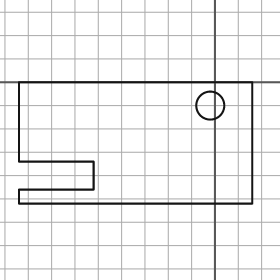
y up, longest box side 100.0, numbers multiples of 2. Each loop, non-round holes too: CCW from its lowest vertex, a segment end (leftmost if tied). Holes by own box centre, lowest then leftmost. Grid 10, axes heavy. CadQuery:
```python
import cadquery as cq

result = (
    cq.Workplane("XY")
    .moveTo(-84.0, -52.0)
    .lineTo(16.0, -52.0)
    .lineTo(16.0, 0.0)
    .lineTo(-84.0, 0.0)
    .lineTo(-84.0, -34.0)
    .lineTo(-52.0, -34.0)
    .lineTo(-52.0, -46.0)
    .lineTo(-84.0, -46.0)
    .close()
    .moveTo(-2.0, -10.0)
    .circle(6.0)
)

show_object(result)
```